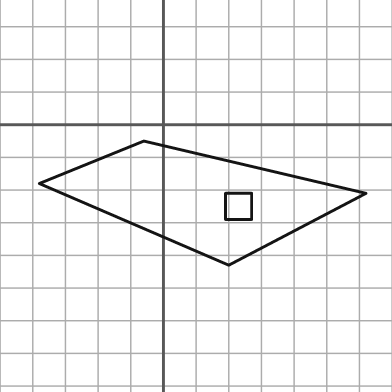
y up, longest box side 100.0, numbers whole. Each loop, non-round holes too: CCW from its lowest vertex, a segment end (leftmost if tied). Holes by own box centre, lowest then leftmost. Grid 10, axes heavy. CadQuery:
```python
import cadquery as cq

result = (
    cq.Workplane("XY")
    .moveTo(20.0, -43.0)
    .lineTo(62.0, -21.0)
    .lineTo(-6.0, -5.0)
    .lineTo(-38.0, -18.0)
    .close()
    .moveTo(19.0, -29.0)
    .lineTo(27.0, -29.0)
    .lineTo(27.0, -21.0)
    .lineTo(19.0, -21.0)
    .close()
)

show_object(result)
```